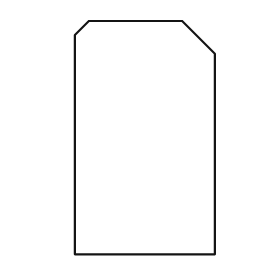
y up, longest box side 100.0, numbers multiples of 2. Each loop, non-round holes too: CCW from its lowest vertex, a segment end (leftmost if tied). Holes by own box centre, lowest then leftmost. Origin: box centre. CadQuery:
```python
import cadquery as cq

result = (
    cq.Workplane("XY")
    .moveTo(-30.0, -50.0)
    .lineTo(30.0, -50.0)
    .lineTo(30.0, 36.0)
    .lineTo(16.0, 50.0)
    .lineTo(-24.0, 50.0)
    .lineTo(-30.0, 44.0)
    .close()
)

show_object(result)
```